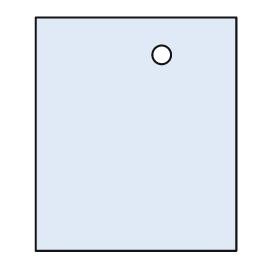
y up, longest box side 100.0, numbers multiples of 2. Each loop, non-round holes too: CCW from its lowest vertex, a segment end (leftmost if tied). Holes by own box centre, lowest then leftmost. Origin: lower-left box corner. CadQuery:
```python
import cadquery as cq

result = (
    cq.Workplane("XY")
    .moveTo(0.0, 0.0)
    .lineTo(86.0, 0.0)
    .lineTo(86.0, 100.0)
    .lineTo(0.0, 100.0)
    .close()
    .moveTo(54.0, 84.0)
    .circle(4.0)
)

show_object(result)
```